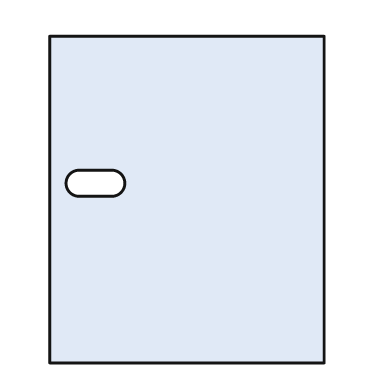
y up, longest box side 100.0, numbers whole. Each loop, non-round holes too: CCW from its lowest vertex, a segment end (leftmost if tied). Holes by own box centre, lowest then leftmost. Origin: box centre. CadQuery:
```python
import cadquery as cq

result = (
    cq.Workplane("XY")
    .moveTo(-42.0, -50.0)
    .lineTo(42.0, -50.0)
    .lineTo(42.0, 50.0)
    .lineTo(-42.0, 50.0)
    .close()
    .moveTo(-33.0, 1.0)
    .lineTo(-23.0, 1.0)
    .threePointArc((-19.0, 5.0), (-23.0, 9.0))
    .lineTo(-33.0, 9.0)
    .threePointArc((-37.0, 5.0), (-33.0, 1.0))
    .close()
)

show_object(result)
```